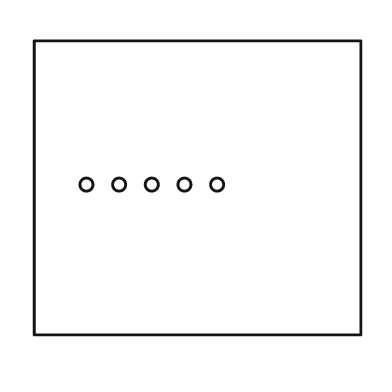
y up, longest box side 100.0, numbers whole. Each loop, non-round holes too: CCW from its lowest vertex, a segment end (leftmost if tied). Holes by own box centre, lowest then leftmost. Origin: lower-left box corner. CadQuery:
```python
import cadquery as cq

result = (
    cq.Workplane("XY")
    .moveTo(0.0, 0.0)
    .lineTo(100.0, 0.0)
    .lineTo(100.0, 90.0)
    .lineTo(0.0, 90.0)
    .close()
    .moveTo(16.0, 46.0)
    .circle(2.0)
    .moveTo(26.0, 46.0)
    .circle(2.0)
    .moveTo(36.0, 46.0)
    .circle(2.0)
    .moveTo(46.0, 46.0)
    .circle(2.0)
    .moveTo(56.0, 46.0)
    .circle(2.0)
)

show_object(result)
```